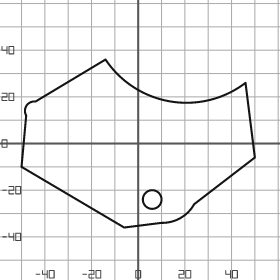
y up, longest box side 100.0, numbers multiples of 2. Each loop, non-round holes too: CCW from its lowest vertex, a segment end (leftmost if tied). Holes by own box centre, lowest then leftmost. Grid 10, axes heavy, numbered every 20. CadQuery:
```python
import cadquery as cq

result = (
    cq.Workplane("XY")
    .moveTo(-6.0, -36.0)
    .lineTo(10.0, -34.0)
    .threePointArc((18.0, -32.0), (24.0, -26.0))
    .lineTo(50.0, -6.0)
    .lineTo(46.0, 26.0)
    .threePointArc((14.0, 18.0), (-14.0, 36.0))
    .lineTo(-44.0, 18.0)
    .threePointArc((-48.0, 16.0), (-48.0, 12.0))
    .lineTo(-50.0, -10.0)
    .close()
    .moveTo(6.0, -24.0)
    .circle(4.0)
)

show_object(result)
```